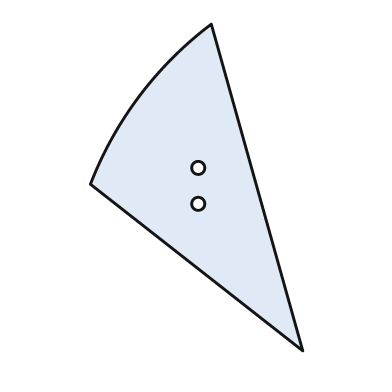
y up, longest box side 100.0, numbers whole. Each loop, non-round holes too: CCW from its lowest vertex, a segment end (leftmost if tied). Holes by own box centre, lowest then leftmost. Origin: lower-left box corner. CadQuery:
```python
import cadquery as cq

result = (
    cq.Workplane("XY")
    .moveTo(65.0, 0.0)
    .lineTo(37.0, 100.0)
    .threePointArc((15.0, 78.0), (0.0, 51.0))
    .close()
    .moveTo(33.0, 45.0)
    .circle(2.0)
    .moveTo(33.0, 56.0)
    .circle(2.0)
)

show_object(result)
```